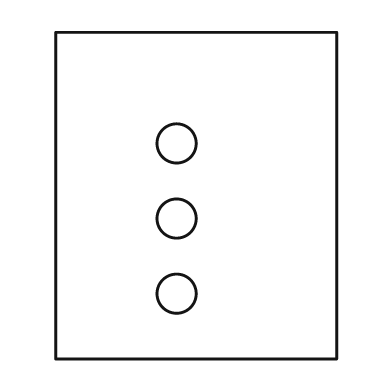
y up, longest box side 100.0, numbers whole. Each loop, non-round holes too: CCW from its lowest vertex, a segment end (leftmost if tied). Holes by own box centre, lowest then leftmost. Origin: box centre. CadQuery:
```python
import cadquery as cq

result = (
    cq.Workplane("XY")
    .moveTo(-43.0, -50.0)
    .lineTo(43.0, -50.0)
    .lineTo(43.0, 50.0)
    .lineTo(-43.0, 50.0)
    .close()
    .moveTo(-6.0, -30.0)
    .circle(6.0)
    .moveTo(-6.0, -7.0)
    .circle(6.0)
    .moveTo(-6.0, 16.0)
    .circle(6.0)
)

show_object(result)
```